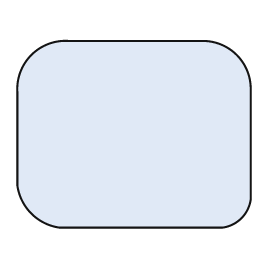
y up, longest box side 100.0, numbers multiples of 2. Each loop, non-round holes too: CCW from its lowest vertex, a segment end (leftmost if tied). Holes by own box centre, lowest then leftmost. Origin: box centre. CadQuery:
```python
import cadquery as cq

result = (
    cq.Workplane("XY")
    .moveTo(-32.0, -40.0)
    .lineTo(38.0, -40.0)
    .threePointArc((46.0, -36.0), (50.0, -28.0))
    .lineTo(50.0, 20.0)
    .threePointArc((44.0, 34.0), (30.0, 40.0))
    .lineTo(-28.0, 40.0)
    .threePointArc((-44.0, 34.0), (-50.0, 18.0))
    .lineTo(-50.0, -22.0)
    .threePointArc((-44.0, -34.0), (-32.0, -40.0))
    .close()
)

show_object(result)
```